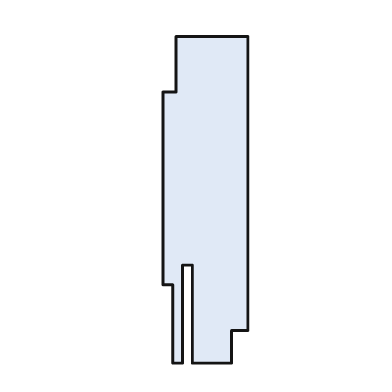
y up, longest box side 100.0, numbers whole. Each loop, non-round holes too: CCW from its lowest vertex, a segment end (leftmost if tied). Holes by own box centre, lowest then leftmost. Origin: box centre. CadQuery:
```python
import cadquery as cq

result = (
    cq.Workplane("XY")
    .moveTo(-10.0, -50.0)
    .lineTo(-7.0, -50.0)
    .lineTo(-7.0, -20.0)
    .lineTo(-4.0, -20.0)
    .lineTo(-4.0, -50.0)
    .lineTo(8.0, -50.0)
    .lineTo(8.0, -40.0)
    .lineTo(13.0, -40.0)
    .lineTo(13.0, 50.0)
    .lineTo(-9.0, 50.0)
    .lineTo(-9.0, 33.0)
    .lineTo(-13.0, 33.0)
    .lineTo(-13.0, -26.0)
    .lineTo(-10.0, -26.0)
    .close()
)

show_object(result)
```